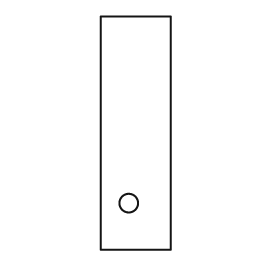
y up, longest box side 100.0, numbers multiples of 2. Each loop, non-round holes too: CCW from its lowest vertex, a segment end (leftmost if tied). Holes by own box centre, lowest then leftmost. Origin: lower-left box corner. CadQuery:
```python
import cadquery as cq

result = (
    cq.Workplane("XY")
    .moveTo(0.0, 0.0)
    .lineTo(30.0, 0.0)
    .lineTo(30.0, 100.0)
    .lineTo(0.0, 100.0)
    .close()
    .moveTo(12.0, 20.0)
    .circle(4.0)
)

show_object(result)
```